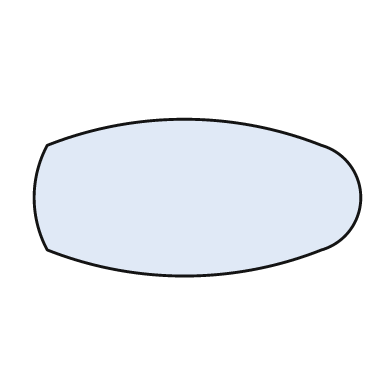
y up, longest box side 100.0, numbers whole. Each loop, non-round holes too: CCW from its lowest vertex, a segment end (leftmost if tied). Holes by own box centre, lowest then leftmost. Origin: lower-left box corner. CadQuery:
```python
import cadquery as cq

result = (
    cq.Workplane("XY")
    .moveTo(4.0, 8.0)
    .threePointArc((46.0, 0.0), (88.0, 8.0))
    .threePointArc((100.0, 24.0), (88.0, 40.0))
    .threePointArc((46.0, 48.0), (4.0, 40.0))
    .threePointArc((0.0, 24.0), (4.0, 8.0))
    .close()
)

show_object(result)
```